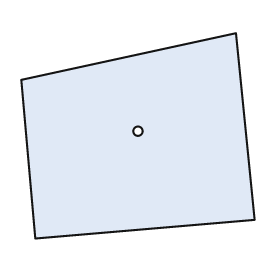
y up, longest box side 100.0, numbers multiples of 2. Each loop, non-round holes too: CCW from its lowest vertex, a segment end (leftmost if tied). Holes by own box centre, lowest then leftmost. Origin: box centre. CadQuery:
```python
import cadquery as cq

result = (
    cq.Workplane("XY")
    .moveTo(-44.0, -44.0)
    .lineTo(50.0, -36.0)
    .lineTo(42.0, 44.0)
    .lineTo(-50.0, 24.0)
    .close()
    .moveTo(0.0, 2.0)
    .circle(2.0)
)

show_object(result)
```